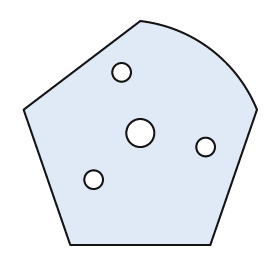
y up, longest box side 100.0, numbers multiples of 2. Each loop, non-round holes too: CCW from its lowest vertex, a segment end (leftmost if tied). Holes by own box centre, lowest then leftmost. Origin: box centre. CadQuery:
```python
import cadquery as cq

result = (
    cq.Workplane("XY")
    .moveTo(-30.0, -48.0)
    .lineTo(30.0, -48.0)
    .lineTo(50.0, 10.0)
    .threePointArc((30.0, 36.0), (0.0, 48.0))
    .lineTo(-50.0, 10.0)
    .close()
    .moveTo(-20.0, -20.0)
    .circle(4.0)
    .moveTo(28.0, -6.0)
    .circle(4.0)
    .moveTo(0.0, 0.0)
    .circle(6.0)
    .moveTo(-8.0, 26.0)
    .circle(4.0)
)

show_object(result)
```